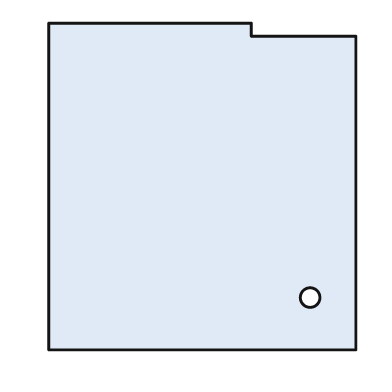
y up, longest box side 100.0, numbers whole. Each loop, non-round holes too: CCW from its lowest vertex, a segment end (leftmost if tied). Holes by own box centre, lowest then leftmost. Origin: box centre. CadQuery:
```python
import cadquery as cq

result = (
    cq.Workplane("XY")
    .moveTo(-47.0, -50.0)
    .lineTo(47.0, -50.0)
    .lineTo(47.0, 46.0)
    .lineTo(15.0, 46.0)
    .lineTo(15.0, 50.0)
    .lineTo(-47.0, 50.0)
    .close()
    .moveTo(33.0, -34.0)
    .circle(3.0)
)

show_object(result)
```